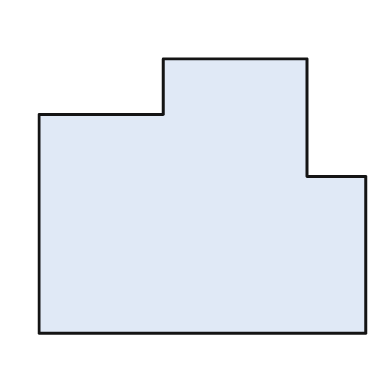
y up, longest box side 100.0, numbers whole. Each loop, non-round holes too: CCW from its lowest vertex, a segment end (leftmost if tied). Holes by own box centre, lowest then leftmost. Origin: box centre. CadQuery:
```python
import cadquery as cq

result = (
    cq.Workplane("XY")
    .moveTo(-50.0, -42.0)
    .lineTo(50.0, -42.0)
    .lineTo(50.0, 6.0)
    .lineTo(32.0, 6.0)
    .lineTo(32.0, 42.0)
    .lineTo(-12.0, 42.0)
    .lineTo(-12.0, 25.0)
    .lineTo(-50.0, 25.0)
    .close()
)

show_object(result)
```